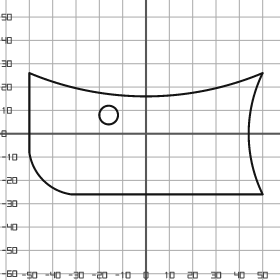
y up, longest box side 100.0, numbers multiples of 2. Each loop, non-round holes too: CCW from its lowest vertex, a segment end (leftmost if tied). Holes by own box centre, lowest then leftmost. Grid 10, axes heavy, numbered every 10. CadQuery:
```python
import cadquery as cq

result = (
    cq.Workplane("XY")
    .moveTo(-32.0, -26.0)
    .lineTo(50.0, -26.0)
    .threePointArc((44.0, 0.0), (50.0, 26.0))
    .threePointArc((0.0, 16.0), (-50.0, 26.0))
    .lineTo(-50.0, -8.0)
    .threePointArc((-44.0, -20.0), (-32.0, -26.0))
    .close()
    .moveTo(-16.0, 8.0)
    .circle(4.0)
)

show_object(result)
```